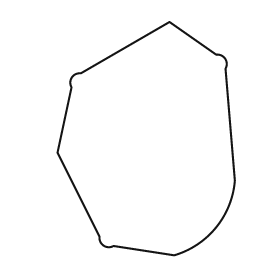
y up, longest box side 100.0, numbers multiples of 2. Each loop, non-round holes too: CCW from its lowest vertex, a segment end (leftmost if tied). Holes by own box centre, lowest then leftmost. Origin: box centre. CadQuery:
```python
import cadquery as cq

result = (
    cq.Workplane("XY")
    .moveTo(12.0, -50.0)
    .threePointArc((30.0, -38.0), (38.0, -18.0))
    .lineTo(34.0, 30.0)
    .threePointArc((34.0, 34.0), (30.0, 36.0))
    .lineTo(10.0, 50.0)
    .lineTo(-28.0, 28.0)
    .threePointArc((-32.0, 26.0), (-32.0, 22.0))
    .lineTo(-38.0, -6.0)
    .lineTo(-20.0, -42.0)
    .threePointArc((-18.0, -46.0), (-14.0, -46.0))
    .close()
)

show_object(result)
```